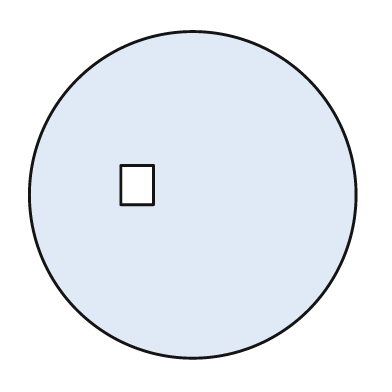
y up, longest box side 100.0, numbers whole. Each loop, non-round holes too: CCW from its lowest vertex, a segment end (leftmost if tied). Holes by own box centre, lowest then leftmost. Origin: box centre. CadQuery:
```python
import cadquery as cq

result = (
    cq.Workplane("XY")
    .moveTo(0.0, 0.0)
    .circle(50.0)
    .moveTo(-22.0, -3.0)
    .lineTo(-12.0, -3.0)
    .lineTo(-12.0, 9.0)
    .lineTo(-22.0, 9.0)
    .close()
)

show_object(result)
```